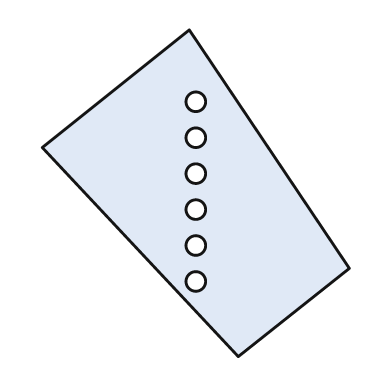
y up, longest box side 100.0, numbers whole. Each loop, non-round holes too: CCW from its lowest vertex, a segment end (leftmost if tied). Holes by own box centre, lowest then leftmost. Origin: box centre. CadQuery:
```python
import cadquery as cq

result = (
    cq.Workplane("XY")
    .moveTo(13.0, -50.0)
    .lineTo(47.0, -23.0)
    .lineTo(-2.0, 50.0)
    .lineTo(-47.0, 14.0)
    .close()
    .moveTo(0.0, -27.0)
    .circle(3.0)
    .moveTo(0.0, -16.0)
    .circle(3.0)
    .moveTo(0.0, -5.0)
    .circle(3.0)
    .moveTo(0.0, 6.0)
    .circle(3.0)
    .moveTo(0.0, 17.0)
    .circle(3.0)
    .moveTo(0.0, 28.0)
    .circle(3.0)
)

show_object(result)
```